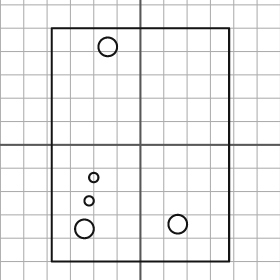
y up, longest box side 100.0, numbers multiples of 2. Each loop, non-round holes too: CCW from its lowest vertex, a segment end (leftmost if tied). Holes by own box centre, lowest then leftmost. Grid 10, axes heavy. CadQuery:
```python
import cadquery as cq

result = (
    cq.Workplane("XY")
    .moveTo(-38.0, -50.0)
    .lineTo(38.0, -50.0)
    .lineTo(38.0, 50.0)
    .lineTo(-38.0, 50.0)
    .close()
    .moveTo(-24.0, -36.0)
    .circle(4.0)
    .moveTo(16.0, -34.0)
    .circle(4.0)
    .moveTo(-22.0, -24.0)
    .circle(2.0)
    .moveTo(-20.0, -14.0)
    .circle(2.0)
    .moveTo(-14.0, 42.0)
    .circle(4.0)
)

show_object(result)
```